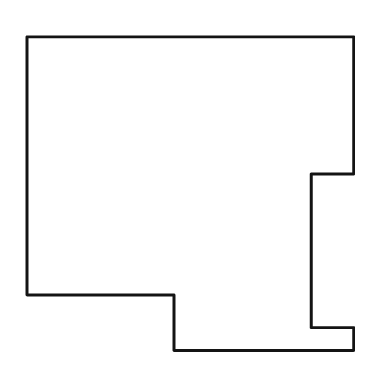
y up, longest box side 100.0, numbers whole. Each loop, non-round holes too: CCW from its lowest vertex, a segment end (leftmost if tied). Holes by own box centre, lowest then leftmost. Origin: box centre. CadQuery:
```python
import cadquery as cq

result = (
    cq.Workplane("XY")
    .moveTo(-5.0, -48.0)
    .lineTo(50.0, -48.0)
    .lineTo(50.0, -41.0)
    .lineTo(37.0, -41.0)
    .lineTo(37.0, 6.0)
    .lineTo(50.0, 6.0)
    .lineTo(50.0, 48.0)
    .lineTo(-50.0, 48.0)
    .lineTo(-50.0, -31.0)
    .lineTo(-5.0, -31.0)
    .close()
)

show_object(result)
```